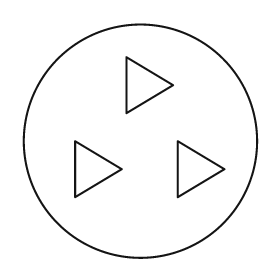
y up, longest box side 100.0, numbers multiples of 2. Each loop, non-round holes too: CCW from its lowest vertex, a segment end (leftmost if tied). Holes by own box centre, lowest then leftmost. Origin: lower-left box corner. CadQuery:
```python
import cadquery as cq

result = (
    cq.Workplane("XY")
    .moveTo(50.0, 50.0)
    .circle(50.0)
    .moveTo(22.0, 26.0)
    .lineTo(42.0, 38.0)
    .lineTo(22.0, 50.0)
    .close()
    .moveTo(66.0, 26.0)
    .lineTo(86.0, 38.0)
    .lineTo(66.0, 50.0)
    .close()
    .moveTo(44.0, 62.0)
    .lineTo(64.0, 74.0)
    .lineTo(44.0, 86.0)
    .close()
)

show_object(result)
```